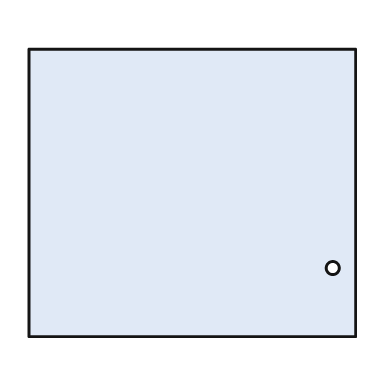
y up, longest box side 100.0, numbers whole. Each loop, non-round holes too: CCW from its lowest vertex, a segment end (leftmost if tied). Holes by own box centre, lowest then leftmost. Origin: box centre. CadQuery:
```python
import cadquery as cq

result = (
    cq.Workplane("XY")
    .moveTo(-50.0, -44.0)
    .lineTo(50.0, -44.0)
    .lineTo(50.0, 44.0)
    .lineTo(-50.0, 44.0)
    .close()
    .moveTo(43.0, -23.0)
    .circle(2.0)
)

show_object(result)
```